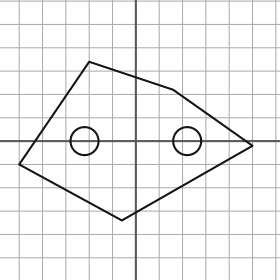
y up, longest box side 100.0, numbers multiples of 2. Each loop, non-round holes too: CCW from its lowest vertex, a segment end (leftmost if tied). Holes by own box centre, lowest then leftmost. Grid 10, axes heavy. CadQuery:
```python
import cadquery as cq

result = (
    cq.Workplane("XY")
    .moveTo(-6.0, -34.0)
    .lineTo(50.0, -2.0)
    .lineTo(16.0, 22.0)
    .lineTo(-20.0, 34.0)
    .lineTo(-50.0, -10.0)
    .close()
    .moveTo(-22.0, 0.0)
    .circle(6.0)
    .moveTo(22.0, 0.0)
    .circle(6.0)
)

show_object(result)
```